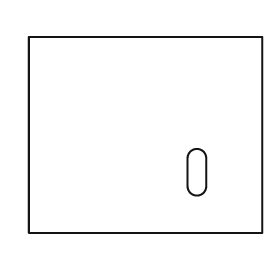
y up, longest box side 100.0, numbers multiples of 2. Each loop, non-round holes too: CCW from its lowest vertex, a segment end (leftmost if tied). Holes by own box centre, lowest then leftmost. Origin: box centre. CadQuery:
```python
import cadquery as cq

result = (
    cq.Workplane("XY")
    .moveTo(-50.0, -42.0)
    .lineTo(50.0, -42.0)
    .lineTo(50.0, 42.0)
    .lineTo(-50.0, 42.0)
    .close()
    .moveTo(18.0, -22.0)
    .threePointArc((22.0, -26.0), (26.0, -22.0))
    .lineTo(26.0, -10.0)
    .threePointArc((22.0, -6.0), (18.0, -10.0))
    .close()
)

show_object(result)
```